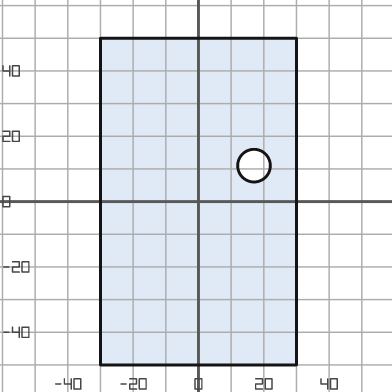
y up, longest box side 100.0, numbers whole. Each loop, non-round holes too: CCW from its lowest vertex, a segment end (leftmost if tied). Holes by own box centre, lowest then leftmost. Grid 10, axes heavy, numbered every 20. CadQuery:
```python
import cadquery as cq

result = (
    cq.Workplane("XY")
    .moveTo(-30.0, -50.0)
    .lineTo(30.0, -50.0)
    .lineTo(30.0, 50.0)
    .lineTo(-30.0, 50.0)
    .close()
    .moveTo(17.0, 11.0)
    .circle(5.0)
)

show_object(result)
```